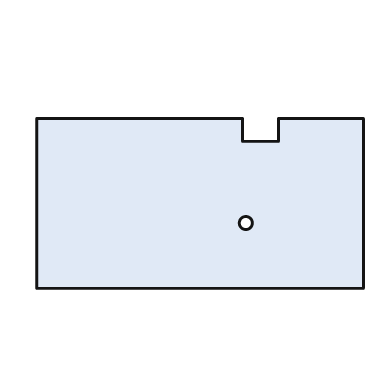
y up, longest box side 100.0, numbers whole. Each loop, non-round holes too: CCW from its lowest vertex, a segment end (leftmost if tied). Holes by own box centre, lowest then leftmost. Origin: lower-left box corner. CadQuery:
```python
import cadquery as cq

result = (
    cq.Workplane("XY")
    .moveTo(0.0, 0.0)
    .lineTo(100.0, 0.0)
    .lineTo(100.0, 52.0)
    .lineTo(74.0, 52.0)
    .lineTo(74.0, 45.0)
    .lineTo(63.0, 45.0)
    .lineTo(63.0, 52.0)
    .lineTo(0.0, 52.0)
    .close()
    .moveTo(64.0, 20.0)
    .circle(2.0)
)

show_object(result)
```